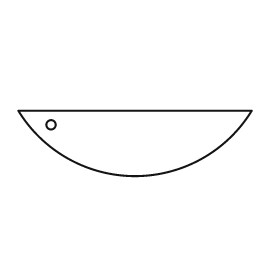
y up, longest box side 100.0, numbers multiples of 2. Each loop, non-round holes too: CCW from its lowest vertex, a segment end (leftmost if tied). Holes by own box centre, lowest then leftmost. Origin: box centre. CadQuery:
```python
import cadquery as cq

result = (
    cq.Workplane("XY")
    .moveTo(-50.0, 14.0)
    .threePointArc((0.0, -14.0), (50.0, 14.0))
    .close()
    .moveTo(-36.0, 8.0)
    .circle(2.0)
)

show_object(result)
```